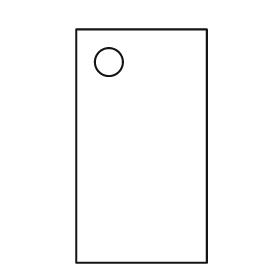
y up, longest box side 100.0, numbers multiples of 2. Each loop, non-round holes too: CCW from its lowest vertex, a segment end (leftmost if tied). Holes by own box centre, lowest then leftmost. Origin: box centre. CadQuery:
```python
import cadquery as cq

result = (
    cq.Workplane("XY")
    .moveTo(-28.0, -50.0)
    .lineTo(28.0, -50.0)
    .lineTo(28.0, 50.0)
    .lineTo(-28.0, 50.0)
    .close()
    .moveTo(-14.0, 36.0)
    .circle(6.0)
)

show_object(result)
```